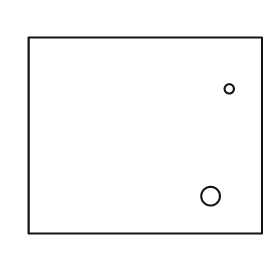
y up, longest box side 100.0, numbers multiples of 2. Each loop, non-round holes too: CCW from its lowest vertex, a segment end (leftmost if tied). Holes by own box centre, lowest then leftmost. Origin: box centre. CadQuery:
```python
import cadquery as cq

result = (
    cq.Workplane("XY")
    .moveTo(-50.0, -42.0)
    .lineTo(50.0, -42.0)
    .lineTo(50.0, 42.0)
    .lineTo(-50.0, 42.0)
    .close()
    .moveTo(28.0, -26.0)
    .circle(4.0)
    .moveTo(36.0, 20.0)
    .circle(2.0)
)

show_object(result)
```